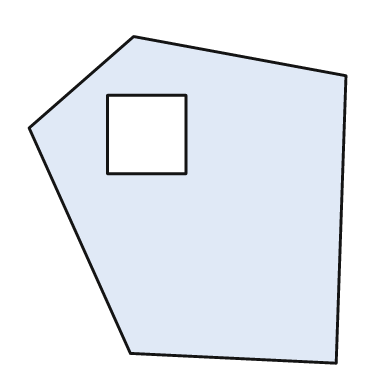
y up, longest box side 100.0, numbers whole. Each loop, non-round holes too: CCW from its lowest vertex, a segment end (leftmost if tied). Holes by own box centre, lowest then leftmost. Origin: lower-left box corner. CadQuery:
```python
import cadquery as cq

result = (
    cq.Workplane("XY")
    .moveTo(94.0, 0.0)
    .lineTo(97.0, 88.0)
    .lineTo(32.0, 100.0)
    .lineTo(0.0, 72.0)
    .lineTo(31.0, 3.0)
    .close()
    .moveTo(24.0, 58.0)
    .lineTo(48.0, 58.0)
    .lineTo(48.0, 82.0)
    .lineTo(24.0, 82.0)
    .close()
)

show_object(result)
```